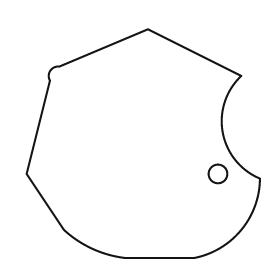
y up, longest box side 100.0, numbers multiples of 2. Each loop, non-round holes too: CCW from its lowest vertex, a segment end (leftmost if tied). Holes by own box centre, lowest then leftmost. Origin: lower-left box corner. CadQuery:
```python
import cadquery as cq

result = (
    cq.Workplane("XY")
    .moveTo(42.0, 0.0)
    .lineTo(72.0, 0.0)
    .threePointArc((92.0, 12.0), (100.0, 34.0))
    .threePointArc((84.0, 54.0), (92.0, 78.0))
    .lineTo(52.0, 98.0)
    .lineTo(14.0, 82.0)
    .threePointArc((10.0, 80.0), (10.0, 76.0))
    .lineTo(0.0, 36.0)
    .lineTo(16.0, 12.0)
    .threePointArc((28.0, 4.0), (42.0, 0.0))
    .close()
    .moveTo(82.0, 36.0)
    .circle(4.0)
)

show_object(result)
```